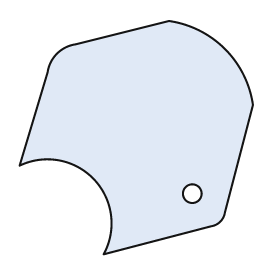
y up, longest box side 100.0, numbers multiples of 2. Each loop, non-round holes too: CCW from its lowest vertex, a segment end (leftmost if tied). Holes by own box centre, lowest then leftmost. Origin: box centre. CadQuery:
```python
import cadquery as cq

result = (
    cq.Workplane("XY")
    .moveTo(-14.0, -50.0)
    .lineTo(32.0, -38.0)
    .threePointArc((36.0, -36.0), (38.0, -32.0))
    .lineTo(50.0, 14.0)
    .threePointArc((38.0, 38.0), (14.0, 50.0))
    .lineTo(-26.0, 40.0)
    .threePointArc((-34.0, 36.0), (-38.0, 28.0))
    .lineTo(-50.0, -12.0)
    .threePointArc((-18.0, -18.0), (-14.0, -50.0))
    .close()
    .moveTo(24.0, -24.0)
    .circle(4.0)
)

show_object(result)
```